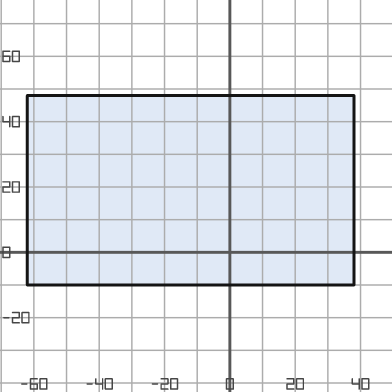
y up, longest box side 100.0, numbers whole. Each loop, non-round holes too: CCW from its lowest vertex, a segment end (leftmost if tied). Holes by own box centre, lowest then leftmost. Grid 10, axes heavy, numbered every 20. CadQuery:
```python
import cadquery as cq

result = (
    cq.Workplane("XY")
    .moveTo(-62.0, -10.0)
    .lineTo(38.0, -10.0)
    .lineTo(38.0, 48.0)
    .lineTo(-62.0, 48.0)
    .close()
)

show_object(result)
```